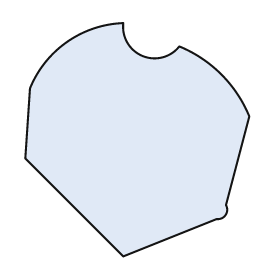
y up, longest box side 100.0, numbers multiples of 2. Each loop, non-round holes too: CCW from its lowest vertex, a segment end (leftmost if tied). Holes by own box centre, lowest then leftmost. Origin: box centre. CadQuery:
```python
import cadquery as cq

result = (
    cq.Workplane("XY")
    .moveTo(-6.0, -50.0)
    .lineTo(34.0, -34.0)
    .threePointArc((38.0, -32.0), (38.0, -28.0))
    .lineTo(48.0, 10.0)
    .threePointArc((36.0, 28.0), (18.0, 40.0))
    .threePointArc((2.0, 36.0), (-6.0, 50.0))
    .threePointArc((-30.0, 42.0), (-46.0, 22.0))
    .lineTo(-48.0, -8.0)
    .close()
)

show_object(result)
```